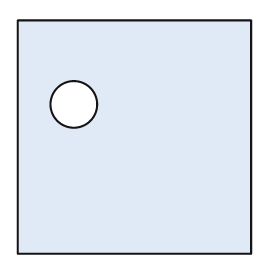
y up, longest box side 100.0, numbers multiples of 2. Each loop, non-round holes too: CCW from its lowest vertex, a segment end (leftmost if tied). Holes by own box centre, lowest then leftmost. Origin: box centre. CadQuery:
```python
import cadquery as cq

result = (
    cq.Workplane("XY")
    .moveTo(-50.0, -50.0)
    .lineTo(50.0, -50.0)
    .lineTo(50.0, 50.0)
    .lineTo(-50.0, 50.0)
    .close()
    .moveTo(-26.0, 14.0)
    .circle(10.0)
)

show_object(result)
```